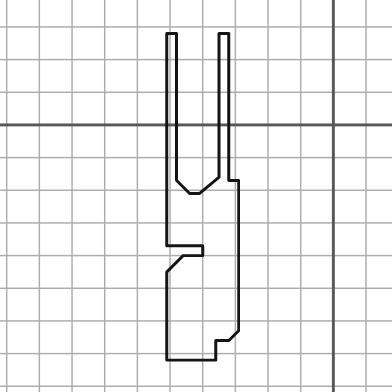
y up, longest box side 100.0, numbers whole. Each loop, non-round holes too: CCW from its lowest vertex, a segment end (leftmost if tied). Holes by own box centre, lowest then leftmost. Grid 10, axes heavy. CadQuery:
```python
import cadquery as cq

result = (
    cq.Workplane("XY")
    .moveTo(-51.0, -72.0)
    .lineTo(-36.0, -72.0)
    .lineTo(-36.0, -66.0)
    .lineTo(-32.0, -66.0)
    .lineTo(-29.0, -63.0)
    .lineTo(-29.0, -17.0)
    .lineTo(-32.0, -17.0)
    .lineTo(-32.0, 28.0)
    .lineTo(-35.0, 28.0)
    .lineTo(-35.0, -16.0)
    .lineTo(-41.0, -21.0)
    .lineTo(-44.0, -21.0)
    .lineTo(-48.0, -17.0)
    .lineTo(-48.0, 28.0)
    .lineTo(-51.0, 28.0)
    .lineTo(-51.0, -37.0)
    .lineTo(-40.0, -37.0)
    .lineTo(-40.0, -40.0)
    .lineTo(-46.0, -40.0)
    .lineTo(-51.0, -45.0)
    .close()
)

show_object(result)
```